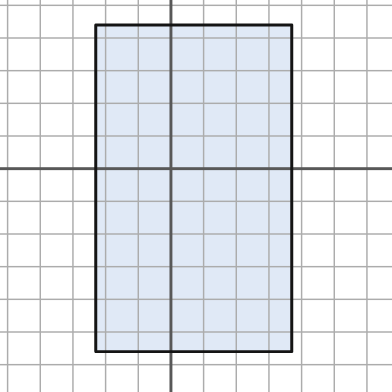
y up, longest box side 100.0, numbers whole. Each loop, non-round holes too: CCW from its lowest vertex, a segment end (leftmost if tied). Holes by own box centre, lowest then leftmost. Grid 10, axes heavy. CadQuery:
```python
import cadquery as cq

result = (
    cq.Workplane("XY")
    .moveTo(-23.0, -56.0)
    .lineTo(37.0, -56.0)
    .lineTo(37.0, 44.0)
    .lineTo(-23.0, 44.0)
    .close()
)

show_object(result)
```